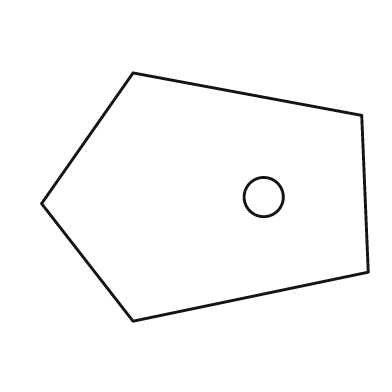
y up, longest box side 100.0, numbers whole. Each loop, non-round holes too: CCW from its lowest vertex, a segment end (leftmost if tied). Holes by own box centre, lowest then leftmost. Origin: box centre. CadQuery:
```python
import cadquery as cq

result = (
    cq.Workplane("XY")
    .moveTo(-22.0, -38.0)
    .lineTo(50.0, -23.0)
    .lineTo(48.0, 25.0)
    .lineTo(-22.0, 38.0)
    .lineTo(-50.0, -2.0)
    .close()
    .moveTo(18.0, 0.0)
    .circle(6.0)
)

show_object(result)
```